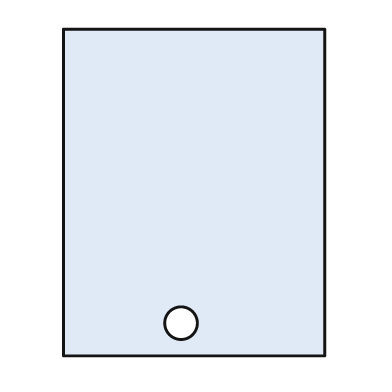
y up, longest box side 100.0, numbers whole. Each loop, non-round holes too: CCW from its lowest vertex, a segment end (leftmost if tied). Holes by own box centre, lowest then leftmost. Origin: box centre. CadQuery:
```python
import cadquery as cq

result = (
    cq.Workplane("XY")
    .moveTo(-40.0, -50.0)
    .lineTo(40.0, -50.0)
    .lineTo(40.0, 50.0)
    .lineTo(-40.0, 50.0)
    .close()
    .moveTo(-4.0, -40.0)
    .circle(5.0)
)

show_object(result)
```